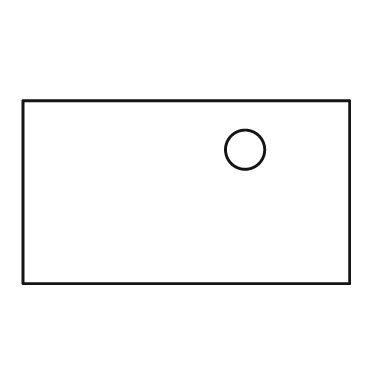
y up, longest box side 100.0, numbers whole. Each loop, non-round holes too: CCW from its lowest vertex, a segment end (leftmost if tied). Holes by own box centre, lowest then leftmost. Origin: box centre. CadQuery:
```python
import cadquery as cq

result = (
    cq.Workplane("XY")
    .moveTo(-50.0, -28.0)
    .lineTo(50.0, -28.0)
    .lineTo(50.0, 28.0)
    .lineTo(-50.0, 28.0)
    .close()
    .moveTo(18.0, 13.0)
    .circle(6.0)
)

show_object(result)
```